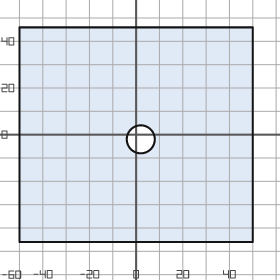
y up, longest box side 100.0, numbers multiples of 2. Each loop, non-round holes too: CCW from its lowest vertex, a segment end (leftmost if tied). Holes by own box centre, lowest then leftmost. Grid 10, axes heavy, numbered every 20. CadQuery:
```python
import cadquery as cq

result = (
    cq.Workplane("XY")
    .moveTo(-50.0, -46.0)
    .lineTo(50.0, -46.0)
    .lineTo(50.0, 46.0)
    .lineTo(-50.0, 46.0)
    .close()
    .moveTo(2.0, -2.0)
    .circle(6.0)
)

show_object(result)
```